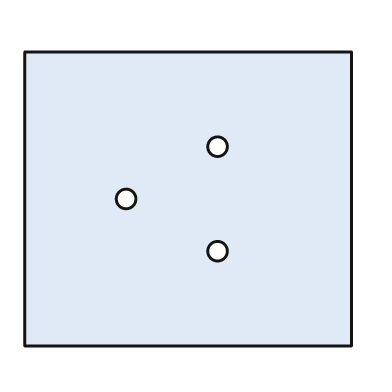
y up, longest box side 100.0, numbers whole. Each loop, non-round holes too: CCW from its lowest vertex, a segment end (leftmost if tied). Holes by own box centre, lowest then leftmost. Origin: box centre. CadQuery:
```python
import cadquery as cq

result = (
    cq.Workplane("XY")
    .moveTo(-50.0, -45.0)
    .lineTo(50.0, -45.0)
    .lineTo(50.0, 45.0)
    .lineTo(-50.0, 45.0)
    .close()
    .moveTo(9.0, -16.0)
    .circle(3.0)
    .moveTo(-19.0, 0.0)
    .circle(3.0)
    .moveTo(9.0, 16.0)
    .circle(3.0)
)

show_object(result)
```